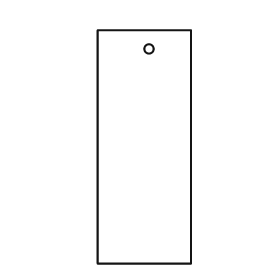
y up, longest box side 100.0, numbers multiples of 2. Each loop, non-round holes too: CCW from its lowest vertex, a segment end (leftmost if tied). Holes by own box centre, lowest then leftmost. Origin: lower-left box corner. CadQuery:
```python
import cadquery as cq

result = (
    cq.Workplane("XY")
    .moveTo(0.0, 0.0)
    .lineTo(40.0, 0.0)
    .lineTo(40.0, 100.0)
    .lineTo(0.0, 100.0)
    .close()
    .moveTo(22.0, 92.0)
    .circle(2.0)
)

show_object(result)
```